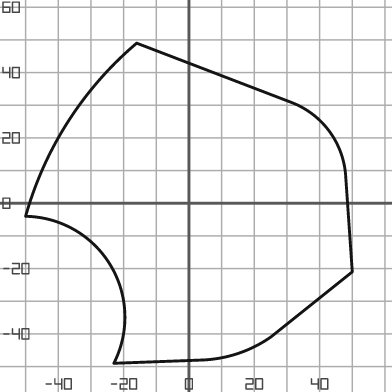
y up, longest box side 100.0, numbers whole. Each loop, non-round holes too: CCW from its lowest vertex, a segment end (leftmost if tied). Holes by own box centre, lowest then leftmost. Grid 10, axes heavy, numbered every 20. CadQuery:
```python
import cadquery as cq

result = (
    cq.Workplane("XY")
    .moveTo(-23.0, -49.0)
    .lineTo(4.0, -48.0)
    .threePointArc((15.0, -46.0), (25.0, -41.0))
    .lineTo(50.0, -21.0)
    .lineTo(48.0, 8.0)
    .threePointArc((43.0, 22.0), (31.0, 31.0))
    .lineTo(-16.0, 49.0)
    .threePointArc((-37.0, 25.0), (-50.0, -4.0))
    .threePointArc((-24.0, -19.0), (-23.0, -49.0))
    .close()
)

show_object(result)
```